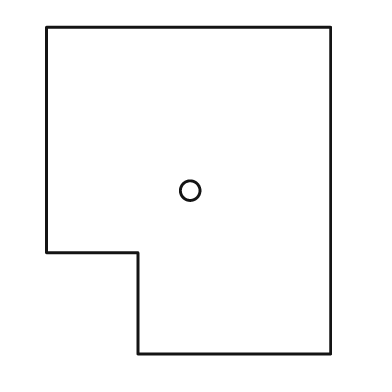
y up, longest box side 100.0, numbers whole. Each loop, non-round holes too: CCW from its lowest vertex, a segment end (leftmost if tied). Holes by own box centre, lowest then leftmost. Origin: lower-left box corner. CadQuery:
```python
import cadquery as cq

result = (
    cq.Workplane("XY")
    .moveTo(28.0, 0.0)
    .lineTo(87.0, 0.0)
    .lineTo(87.0, 100.0)
    .lineTo(0.0, 100.0)
    .lineTo(0.0, 31.0)
    .lineTo(28.0, 31.0)
    .close()
    .moveTo(44.0, 50.0)
    .circle(3.0)
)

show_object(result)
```